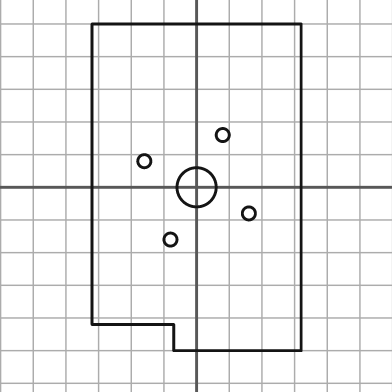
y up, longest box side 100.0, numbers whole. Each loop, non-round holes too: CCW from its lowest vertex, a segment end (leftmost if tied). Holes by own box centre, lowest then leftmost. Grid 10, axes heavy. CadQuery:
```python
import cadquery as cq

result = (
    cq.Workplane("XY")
    .moveTo(-7.0, -50.0)
    .lineTo(32.0, -50.0)
    .lineTo(32.0, 50.0)
    .lineTo(-32.0, 50.0)
    .lineTo(-32.0, -42.0)
    .lineTo(-7.0, -42.0)
    .close()
    .moveTo(-8.0, -16.0)
    .circle(2.0)
    .moveTo(16.0, -8.0)
    .circle(2.0)
    .moveTo(0.0, 0.0)
    .circle(6.0)
    .moveTo(-16.0, 8.0)
    .circle(2.0)
    .moveTo(8.0, 16.0)
    .circle(2.0)
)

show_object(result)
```